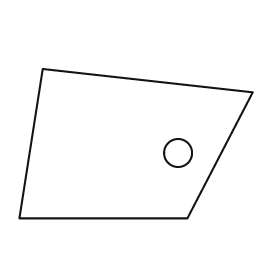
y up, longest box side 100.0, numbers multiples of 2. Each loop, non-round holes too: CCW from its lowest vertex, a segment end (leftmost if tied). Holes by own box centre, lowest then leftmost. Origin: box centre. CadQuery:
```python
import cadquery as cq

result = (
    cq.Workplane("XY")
    .moveTo(-50.0, -32.0)
    .lineTo(22.0, -32.0)
    .lineTo(50.0, 22.0)
    .lineTo(-40.0, 32.0)
    .close()
    .moveTo(18.0, -4.0)
    .circle(6.0)
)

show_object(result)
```